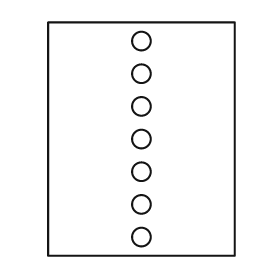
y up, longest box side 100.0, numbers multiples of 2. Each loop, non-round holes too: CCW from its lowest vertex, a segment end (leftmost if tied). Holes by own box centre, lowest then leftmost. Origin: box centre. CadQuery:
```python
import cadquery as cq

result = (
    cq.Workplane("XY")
    .moveTo(-40.0, -50.0)
    .lineTo(40.0, -50.0)
    .lineTo(40.0, 50.0)
    .lineTo(-40.0, 50.0)
    .close()
    .moveTo(0.0, -42.0)
    .circle(4.0)
    .moveTo(0.0, -28.0)
    .circle(4.0)
    .moveTo(0.0, -14.0)
    .circle(4.0)
    .moveTo(0.0, 0.0)
    .circle(4.0)
    .moveTo(0.0, 14.0)
    .circle(4.0)
    .moveTo(0.0, 28.0)
    .circle(4.0)
    .moveTo(0.0, 42.0)
    .circle(4.0)
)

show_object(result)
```